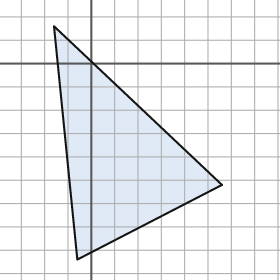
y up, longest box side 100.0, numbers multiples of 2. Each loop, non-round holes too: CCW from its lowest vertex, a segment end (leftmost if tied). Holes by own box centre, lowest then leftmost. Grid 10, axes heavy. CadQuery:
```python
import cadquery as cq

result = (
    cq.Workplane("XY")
    .moveTo(-6.0, -84.0)
    .lineTo(56.0, -52.0)
    .lineTo(-16.0, 16.0)
    .close()
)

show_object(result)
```